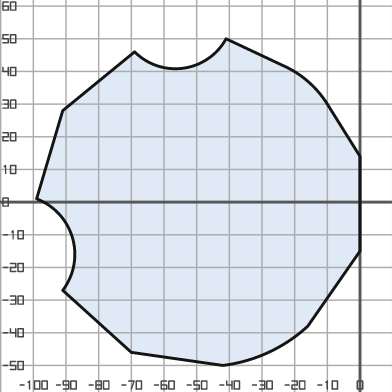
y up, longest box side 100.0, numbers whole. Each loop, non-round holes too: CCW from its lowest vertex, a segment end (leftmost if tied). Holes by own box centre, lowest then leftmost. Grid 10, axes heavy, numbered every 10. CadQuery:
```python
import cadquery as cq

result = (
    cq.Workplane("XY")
    .moveTo(-42.0, -50.0)
    .threePointArc((-28.0, -46.0), (-16.0, -38.0))
    .lineTo(0.0, -15.0)
    .lineTo(0.0, 14.0)
    .lineTo(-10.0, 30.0)
    .threePointArc((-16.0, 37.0), (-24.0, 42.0))
    .lineTo(-41.0, 50.0)
    .threePointArc((-54.0, 41.0), (-69.0, 46.0))
    .lineTo(-91.0, 28.0)
    .lineTo(-99.0, 1.0)
    .threePointArc((-88.0, -11.0), (-91.0, -27.0))
    .lineTo(-70.0, -46.0)
    .close()
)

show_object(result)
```